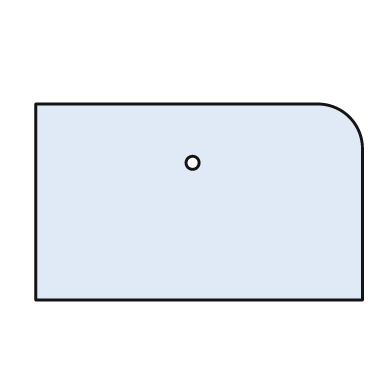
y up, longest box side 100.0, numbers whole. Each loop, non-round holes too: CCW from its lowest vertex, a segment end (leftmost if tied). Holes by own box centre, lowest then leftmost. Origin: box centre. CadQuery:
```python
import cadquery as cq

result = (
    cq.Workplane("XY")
    .moveTo(-50.0, -30.0)
    .lineTo(50.0, -30.0)
    .lineTo(50.0, 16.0)
    .threePointArc((46.0, 26.0), (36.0, 30.0))
    .lineTo(-50.0, 30.0)
    .close()
    .moveTo(-2.0, 12.0)
    .circle(2.0)
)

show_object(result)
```